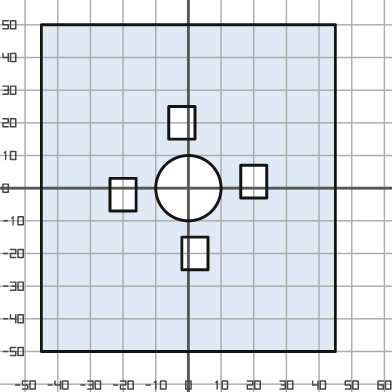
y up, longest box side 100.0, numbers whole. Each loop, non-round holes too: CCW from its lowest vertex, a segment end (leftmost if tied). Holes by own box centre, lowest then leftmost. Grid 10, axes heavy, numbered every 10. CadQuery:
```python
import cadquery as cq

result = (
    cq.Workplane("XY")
    .moveTo(-45.0, -50.0)
    .lineTo(45.0, -50.0)
    .lineTo(45.0, 50.0)
    .lineTo(-45.0, 50.0)
    .close()
    .moveTo(-2.0, -25.0)
    .lineTo(6.0, -25.0)
    .lineTo(6.0, -15.0)
    .lineTo(-2.0, -15.0)
    .close()
    .moveTo(-24.0, -7.0)
    .lineTo(-16.0, -7.0)
    .lineTo(-16.0, 3.0)
    .lineTo(-24.0, 3.0)
    .close()
    .moveTo(0.0, 0.0)
    .circle(10.0)
    .moveTo(16.0, -3.0)
    .lineTo(24.0, -3.0)
    .lineTo(24.0, 7.0)
    .lineTo(16.0, 7.0)
    .close()
    .moveTo(-6.0, 15.0)
    .lineTo(2.0, 15.0)
    .lineTo(2.0, 25.0)
    .lineTo(-6.0, 25.0)
    .close()
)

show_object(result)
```